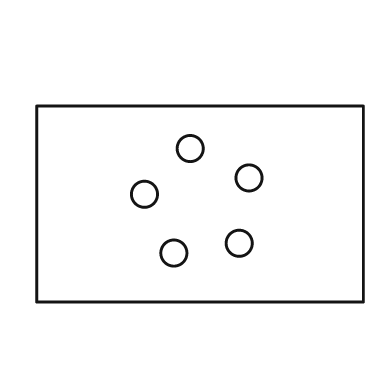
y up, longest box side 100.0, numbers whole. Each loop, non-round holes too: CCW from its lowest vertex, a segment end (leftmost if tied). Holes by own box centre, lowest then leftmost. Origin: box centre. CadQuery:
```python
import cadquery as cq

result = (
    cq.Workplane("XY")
    .moveTo(-50.0, -30.0)
    .lineTo(50.0, -30.0)
    .lineTo(50.0, 30.0)
    .lineTo(-50.0, 30.0)
    .close()
    .moveTo(-8.0, -15.0)
    .circle(4.0)
    .moveTo(12.0, -12.0)
    .circle(4.0)
    .moveTo(-17.0, 3.0)
    .circle(4.0)
    .moveTo(15.0, 8.0)
    .circle(4.0)
    .moveTo(-3.0, 17.0)
    .circle(4.0)
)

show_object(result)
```